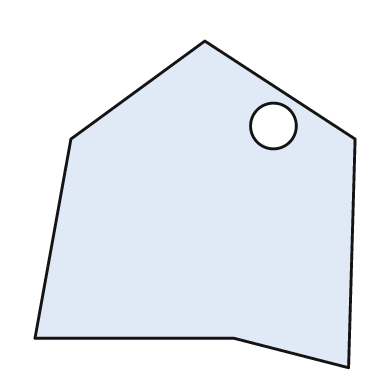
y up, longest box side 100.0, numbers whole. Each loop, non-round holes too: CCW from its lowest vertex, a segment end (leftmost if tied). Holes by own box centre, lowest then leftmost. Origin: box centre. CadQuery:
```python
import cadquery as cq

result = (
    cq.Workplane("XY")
    .moveTo(47.0, -50.0)
    .lineTo(49.0, 20.0)
    .lineTo(3.0, 50.0)
    .lineTo(-38.0, 20.0)
    .lineTo(-49.0, -41.0)
    .lineTo(12.0, -41.0)
    .close()
    .moveTo(24.0, 24.0)
    .circle(7.0)
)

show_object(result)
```